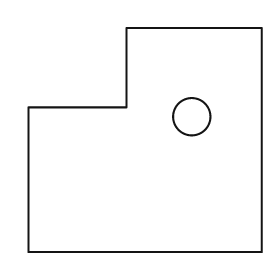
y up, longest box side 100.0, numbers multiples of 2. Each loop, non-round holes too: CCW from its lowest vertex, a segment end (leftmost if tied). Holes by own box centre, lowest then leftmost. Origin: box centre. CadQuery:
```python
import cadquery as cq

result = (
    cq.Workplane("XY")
    .moveTo(-50.0, -48.0)
    .lineTo(50.0, -48.0)
    .lineTo(50.0, 48.0)
    .lineTo(-8.0, 48.0)
    .lineTo(-8.0, 14.0)
    .lineTo(-50.0, 14.0)
    .close()
    .moveTo(20.0, 10.0)
    .circle(8.0)
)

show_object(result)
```